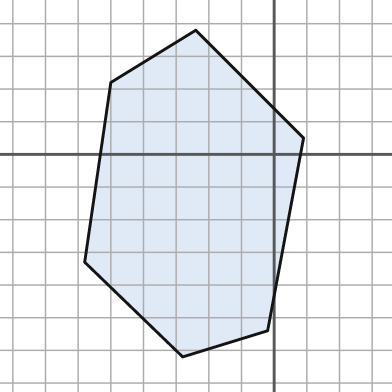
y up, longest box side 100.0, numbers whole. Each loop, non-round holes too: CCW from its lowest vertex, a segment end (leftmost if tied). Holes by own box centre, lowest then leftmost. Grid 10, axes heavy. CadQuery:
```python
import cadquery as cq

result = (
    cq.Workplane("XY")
    .moveTo(-28.0, -62.0)
    .lineTo(-2.0, -54.0)
    .lineTo(9.0, 5.0)
    .lineTo(-24.0, 38.0)
    .lineTo(-50.0, 22.0)
    .lineTo(-58.0, -33.0)
    .close()
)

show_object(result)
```